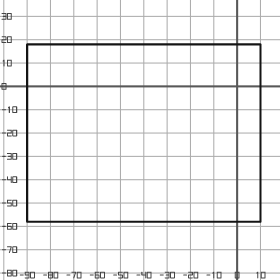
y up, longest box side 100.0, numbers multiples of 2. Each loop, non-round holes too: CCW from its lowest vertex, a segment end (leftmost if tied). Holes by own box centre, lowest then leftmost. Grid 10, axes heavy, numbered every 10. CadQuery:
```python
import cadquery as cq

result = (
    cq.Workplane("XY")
    .moveTo(-90.0, -58.0)
    .lineTo(10.0, -58.0)
    .lineTo(10.0, 18.0)
    .lineTo(-90.0, 18.0)
    .close()
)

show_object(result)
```